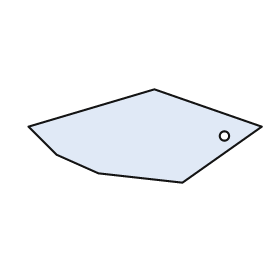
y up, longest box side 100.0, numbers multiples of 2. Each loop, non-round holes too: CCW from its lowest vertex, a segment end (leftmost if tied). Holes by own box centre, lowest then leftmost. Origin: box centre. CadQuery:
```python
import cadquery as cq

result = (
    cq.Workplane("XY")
    .moveTo(16.0, -20.0)
    .lineTo(50.0, 4.0)
    .lineTo(4.0, 20.0)
    .lineTo(-50.0, 4.0)
    .lineTo(-38.0, -8.0)
    .lineTo(-20.0, -16.0)
    .close()
    .moveTo(34.0, 0.0)
    .circle(2.0)
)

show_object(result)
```